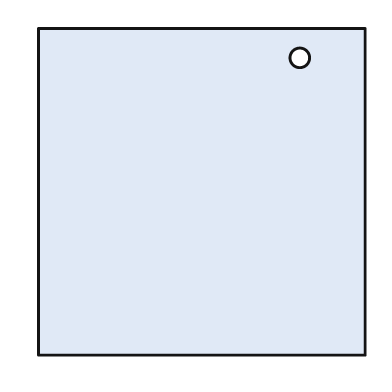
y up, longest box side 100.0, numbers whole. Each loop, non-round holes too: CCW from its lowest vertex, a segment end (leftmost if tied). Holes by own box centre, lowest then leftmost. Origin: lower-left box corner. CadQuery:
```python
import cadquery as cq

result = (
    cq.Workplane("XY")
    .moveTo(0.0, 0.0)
    .lineTo(100.0, 0.0)
    .lineTo(100.0, 100.0)
    .lineTo(0.0, 100.0)
    .close()
    .moveTo(80.0, 91.0)
    .circle(3.0)
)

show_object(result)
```